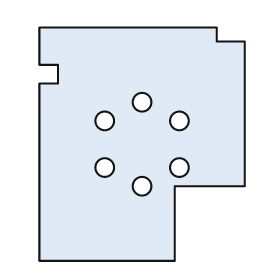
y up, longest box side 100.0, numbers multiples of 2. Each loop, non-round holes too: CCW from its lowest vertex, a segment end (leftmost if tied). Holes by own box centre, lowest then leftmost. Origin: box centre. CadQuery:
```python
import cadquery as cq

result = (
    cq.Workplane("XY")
    .moveTo(-44.0, -50.0)
    .lineTo(14.0, -50.0)
    .lineTo(14.0, -18.0)
    .lineTo(44.0, -18.0)
    .lineTo(44.0, 44.0)
    .lineTo(32.0, 44.0)
    .lineTo(32.0, 50.0)
    .lineTo(-44.0, 50.0)
    .lineTo(-44.0, 34.0)
    .lineTo(-36.0, 34.0)
    .lineTo(-36.0, 26.0)
    .lineTo(-44.0, 26.0)
    .close()
    .moveTo(0.0, -18.0)
    .circle(4.0)
    .moveTo(-16.0, -10.0)
    .circle(4.0)
    .moveTo(16.0, -10.0)
    .circle(4.0)
    .moveTo(-16.0, 10.0)
    .circle(4.0)
    .moveTo(16.0, 10.0)
    .circle(4.0)
    .moveTo(0.0, 18.0)
    .circle(4.0)
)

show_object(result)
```